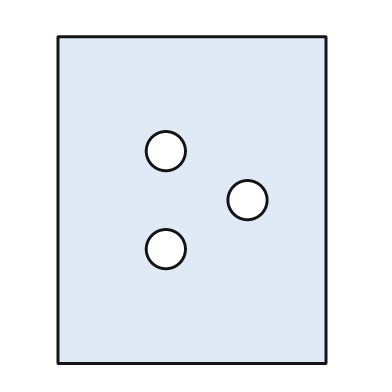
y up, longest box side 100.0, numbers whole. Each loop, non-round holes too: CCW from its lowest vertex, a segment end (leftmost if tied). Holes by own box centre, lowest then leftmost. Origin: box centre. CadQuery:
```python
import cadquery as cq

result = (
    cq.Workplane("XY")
    .moveTo(-41.0, -50.0)
    .lineTo(41.0, -50.0)
    .lineTo(41.0, 50.0)
    .lineTo(-41.0, 50.0)
    .close()
    .moveTo(-8.0, -15.0)
    .circle(6.0)
    .moveTo(17.0, 0.0)
    .circle(6.0)
    .moveTo(-8.0, 15.0)
    .circle(6.0)
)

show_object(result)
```